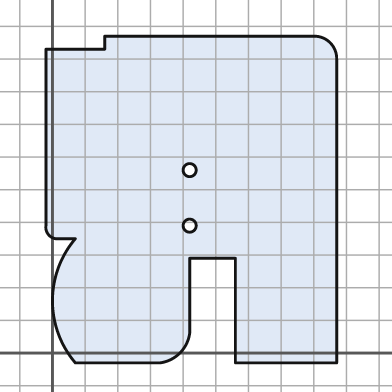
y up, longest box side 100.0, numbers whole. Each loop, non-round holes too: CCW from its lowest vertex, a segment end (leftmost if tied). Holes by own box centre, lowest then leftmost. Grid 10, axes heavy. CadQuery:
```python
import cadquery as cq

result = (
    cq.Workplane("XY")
    .moveTo(7.0, -3.0)
    .lineTo(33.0, -3.0)
    .threePointArc((39.0, 0.0), (42.0, 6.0))
    .lineTo(42.0, 29.0)
    .lineTo(56.0, 29.0)
    .lineTo(56.0, -3.0)
    .lineTo(87.0, -3.0)
    .lineTo(87.0, 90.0)
    .threePointArc((85.0, 95.0), (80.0, 97.0))
    .lineTo(16.0, 97.0)
    .lineTo(16.0, 93.0)
    .lineTo(-2.0, 93.0)
    .lineTo(-2.0, 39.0)
    .threePointArc((-1.0, 36.0), (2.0, 35.0))
    .lineTo(7.0, 35.0)
    .threePointArc((0.0, 16.0), (7.0, -3.0))
    .close()
    .moveTo(42.0, 39.0)
    .circle(2.0)
    .moveTo(42.0, 56.0)
    .circle(2.0)
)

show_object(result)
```